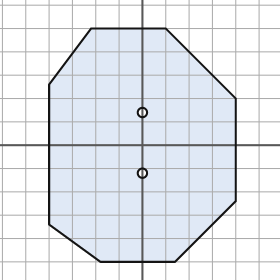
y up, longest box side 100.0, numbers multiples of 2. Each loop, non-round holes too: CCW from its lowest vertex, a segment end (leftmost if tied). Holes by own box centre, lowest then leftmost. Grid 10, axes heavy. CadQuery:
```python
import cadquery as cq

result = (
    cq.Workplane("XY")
    .moveTo(-18.0, -50.0)
    .lineTo(14.0, -50.0)
    .lineTo(40.0, -24.0)
    .lineTo(40.0, 20.0)
    .lineTo(10.0, 50.0)
    .lineTo(-22.0, 50.0)
    .lineTo(-40.0, 26.0)
    .lineTo(-40.0, -34.0)
    .close()
    .moveTo(0.0, -12.0)
    .circle(2.0)
    .moveTo(0.0, 14.0)
    .circle(2.0)
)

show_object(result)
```